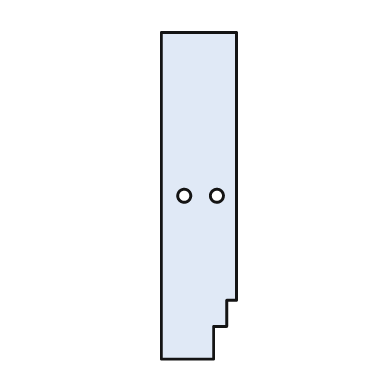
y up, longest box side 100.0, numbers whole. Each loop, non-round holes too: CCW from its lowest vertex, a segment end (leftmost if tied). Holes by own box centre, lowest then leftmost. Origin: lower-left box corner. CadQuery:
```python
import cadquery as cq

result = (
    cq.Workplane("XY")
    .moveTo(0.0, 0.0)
    .lineTo(16.0, 0.0)
    .lineTo(16.0, 10.0)
    .lineTo(20.0, 10.0)
    .lineTo(20.0, 18.0)
    .lineTo(23.0, 18.0)
    .lineTo(23.0, 100.0)
    .lineTo(0.0, 100.0)
    .close()
    .moveTo(7.0, 50.0)
    .circle(2.0)
    .moveTo(17.0, 50.0)
    .circle(2.0)
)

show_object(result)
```